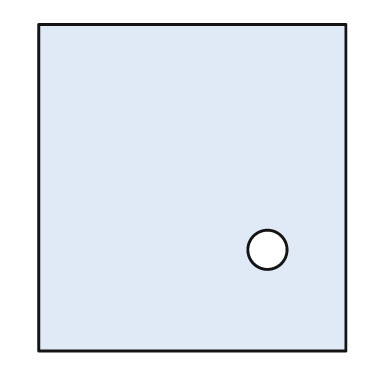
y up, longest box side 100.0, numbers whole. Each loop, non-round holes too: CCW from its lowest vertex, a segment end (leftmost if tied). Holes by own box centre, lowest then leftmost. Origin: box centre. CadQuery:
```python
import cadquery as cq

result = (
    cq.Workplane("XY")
    .moveTo(-47.0, -50.0)
    .lineTo(47.0, -50.0)
    .lineTo(47.0, 50.0)
    .lineTo(-47.0, 50.0)
    .close()
    .moveTo(23.0, -19.0)
    .circle(6.0)
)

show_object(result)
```